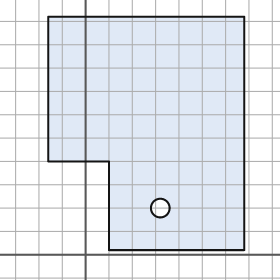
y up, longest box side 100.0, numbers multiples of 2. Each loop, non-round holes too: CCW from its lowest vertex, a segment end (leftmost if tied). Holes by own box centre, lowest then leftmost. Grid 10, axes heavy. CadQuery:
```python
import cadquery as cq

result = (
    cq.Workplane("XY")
    .moveTo(10.0, 2.0)
    .lineTo(68.0, 2.0)
    .lineTo(68.0, 102.0)
    .lineTo(-16.0, 102.0)
    .lineTo(-16.0, 40.0)
    .lineTo(10.0, 40.0)
    .close()
    .moveTo(32.0, 20.0)
    .circle(4.0)
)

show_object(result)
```